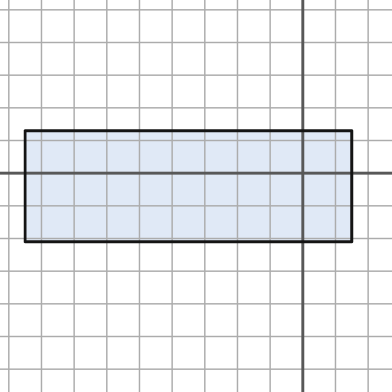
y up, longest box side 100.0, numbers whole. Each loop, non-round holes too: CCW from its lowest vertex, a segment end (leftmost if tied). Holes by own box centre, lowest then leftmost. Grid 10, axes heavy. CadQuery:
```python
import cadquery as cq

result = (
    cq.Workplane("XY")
    .moveTo(-85.0, -21.0)
    .lineTo(15.0, -21.0)
    .lineTo(15.0, 13.0)
    .lineTo(-85.0, 13.0)
    .close()
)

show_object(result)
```